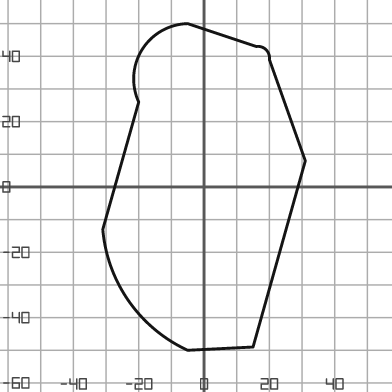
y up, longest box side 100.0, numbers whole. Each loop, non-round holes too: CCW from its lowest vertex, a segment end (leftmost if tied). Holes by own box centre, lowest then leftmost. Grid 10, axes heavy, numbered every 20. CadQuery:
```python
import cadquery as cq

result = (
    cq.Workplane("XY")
    .moveTo(-5.0, -50.0)
    .lineTo(15.0, -49.0)
    .lineTo(31.0, 8.0)
    .lineTo(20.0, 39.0)
    .threePointArc((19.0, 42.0), (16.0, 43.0))
    .lineTo(-5.0, 50.0)
    .threePointArc((-19.0, 42.0), (-20.0, 26.0))
    .lineTo(-31.0, -13.0)
    .threePointArc((-23.0, -35.0), (-5.0, -50.0))
    .close()
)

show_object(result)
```